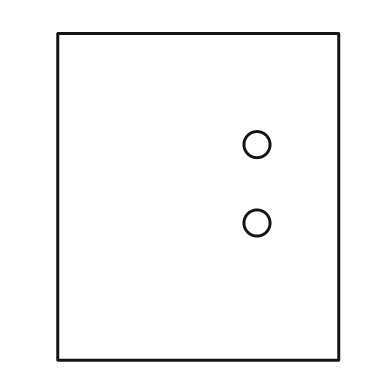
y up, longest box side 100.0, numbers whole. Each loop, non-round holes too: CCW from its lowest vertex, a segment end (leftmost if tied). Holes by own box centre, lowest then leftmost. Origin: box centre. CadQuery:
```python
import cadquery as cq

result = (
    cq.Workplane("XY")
    .moveTo(-43.0, -50.0)
    .lineTo(43.0, -50.0)
    .lineTo(43.0, 50.0)
    .lineTo(-43.0, 50.0)
    .close()
    .moveTo(18.0, -8.0)
    .circle(4.0)
    .moveTo(18.0, 16.0)
    .circle(4.0)
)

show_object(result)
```